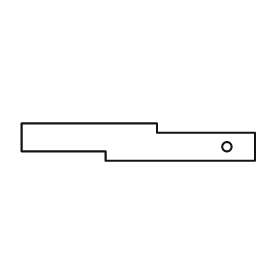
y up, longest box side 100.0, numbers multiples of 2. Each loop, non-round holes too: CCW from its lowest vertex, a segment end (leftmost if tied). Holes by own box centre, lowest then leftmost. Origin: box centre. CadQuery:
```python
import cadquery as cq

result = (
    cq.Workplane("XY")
    .moveTo(-14.0, -8.0)
    .lineTo(50.0, -8.0)
    .lineTo(50.0, 4.0)
    .lineTo(8.0, 4.0)
    .lineTo(8.0, 8.0)
    .lineTo(-50.0, 8.0)
    .lineTo(-50.0, -4.0)
    .lineTo(-14.0, -4.0)
    .close()
    .moveTo(38.0, -2.0)
    .circle(2.0)
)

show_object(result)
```